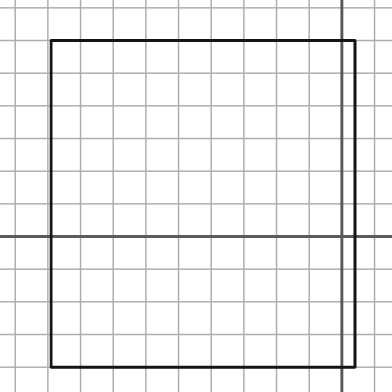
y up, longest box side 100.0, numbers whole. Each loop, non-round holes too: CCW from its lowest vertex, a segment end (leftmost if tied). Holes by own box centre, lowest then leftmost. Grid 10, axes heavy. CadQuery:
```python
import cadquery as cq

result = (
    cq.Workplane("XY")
    .moveTo(-89.0, -40.0)
    .lineTo(4.0, -40.0)
    .lineTo(4.0, 60.0)
    .lineTo(-89.0, 60.0)
    .close()
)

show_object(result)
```